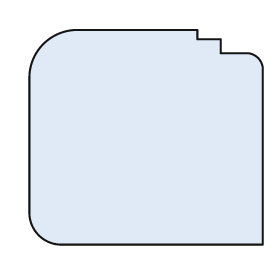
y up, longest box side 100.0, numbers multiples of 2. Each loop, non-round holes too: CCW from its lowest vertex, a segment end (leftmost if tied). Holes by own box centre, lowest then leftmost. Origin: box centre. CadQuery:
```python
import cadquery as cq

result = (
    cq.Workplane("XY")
    .moveTo(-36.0, -46.0)
    .lineTo(50.0, -46.0)
    .lineTo(50.0, 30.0)
    .threePointArc((48.0, 34.0), (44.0, 36.0))
    .lineTo(32.0, 36.0)
    .lineTo(32.0, 42.0)
    .lineTo(22.0, 42.0)
    .lineTo(22.0, 46.0)
    .lineTo(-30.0, 46.0)
    .threePointArc((-44.0, 40.0), (-50.0, 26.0))
    .lineTo(-50.0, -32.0)
    .threePointArc((-46.0, -42.0), (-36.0, -46.0))
    .close()
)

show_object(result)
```